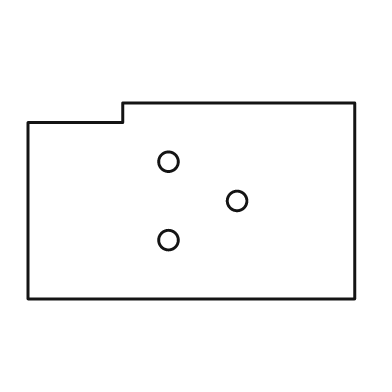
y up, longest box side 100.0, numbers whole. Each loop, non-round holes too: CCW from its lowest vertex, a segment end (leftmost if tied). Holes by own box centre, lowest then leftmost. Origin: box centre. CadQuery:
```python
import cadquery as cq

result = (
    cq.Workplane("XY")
    .moveTo(-50.0, -30.0)
    .lineTo(50.0, -30.0)
    .lineTo(50.0, 30.0)
    .lineTo(-21.0, 30.0)
    .lineTo(-21.0, 24.0)
    .lineTo(-50.0, 24.0)
    .close()
    .moveTo(-7.0, -12.0)
    .circle(3.0)
    .moveTo(14.0, 0.0)
    .circle(3.0)
    .moveTo(-7.0, 12.0)
    .circle(3.0)
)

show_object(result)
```